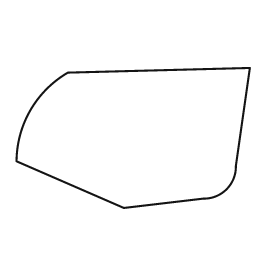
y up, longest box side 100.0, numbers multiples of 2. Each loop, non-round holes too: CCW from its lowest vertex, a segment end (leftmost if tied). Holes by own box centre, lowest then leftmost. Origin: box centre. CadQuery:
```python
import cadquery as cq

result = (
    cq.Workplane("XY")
    .moveTo(-4.0, -30.0)
    .lineTo(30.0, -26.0)
    .threePointArc((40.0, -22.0), (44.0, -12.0))
    .lineTo(50.0, 30.0)
    .lineTo(-28.0, 28.0)
    .threePointArc((-44.0, 12.0), (-50.0, -10.0))
    .close()
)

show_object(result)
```